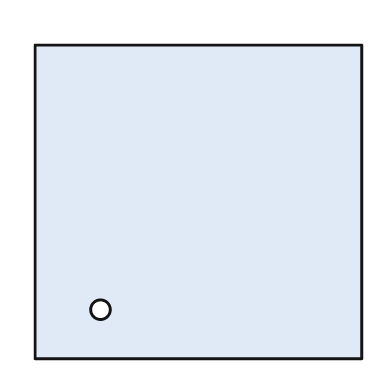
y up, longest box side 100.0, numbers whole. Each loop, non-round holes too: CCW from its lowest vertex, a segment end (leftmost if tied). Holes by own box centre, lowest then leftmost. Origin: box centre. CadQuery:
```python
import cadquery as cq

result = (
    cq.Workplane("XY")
    .moveTo(-50.0, -48.0)
    .lineTo(50.0, -48.0)
    .lineTo(50.0, 48.0)
    .lineTo(-50.0, 48.0)
    .close()
    .moveTo(-30.0, -33.0)
    .circle(3.0)
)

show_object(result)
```